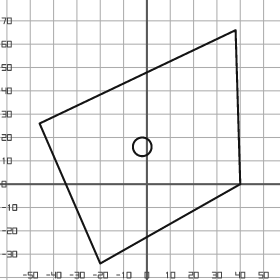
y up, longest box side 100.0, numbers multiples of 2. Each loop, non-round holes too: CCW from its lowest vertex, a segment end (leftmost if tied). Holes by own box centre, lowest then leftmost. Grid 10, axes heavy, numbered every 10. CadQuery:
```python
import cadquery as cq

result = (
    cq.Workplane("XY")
    .moveTo(-20.0, -34.0)
    .lineTo(40.0, 0.0)
    .lineTo(38.0, 66.0)
    .lineTo(-46.0, 26.0)
    .close()
    .moveTo(-2.0, 16.0)
    .circle(4.0)
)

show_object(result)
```